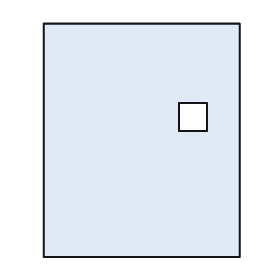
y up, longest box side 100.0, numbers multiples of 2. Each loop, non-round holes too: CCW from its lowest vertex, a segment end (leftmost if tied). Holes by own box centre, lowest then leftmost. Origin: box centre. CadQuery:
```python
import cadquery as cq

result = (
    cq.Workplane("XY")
    .moveTo(-42.0, -50.0)
    .lineTo(42.0, -50.0)
    .lineTo(42.0, 50.0)
    .lineTo(-42.0, 50.0)
    .close()
    .moveTo(16.0, 4.0)
    .lineTo(28.0, 4.0)
    .lineTo(28.0, 16.0)
    .lineTo(16.0, 16.0)
    .close()
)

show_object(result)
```